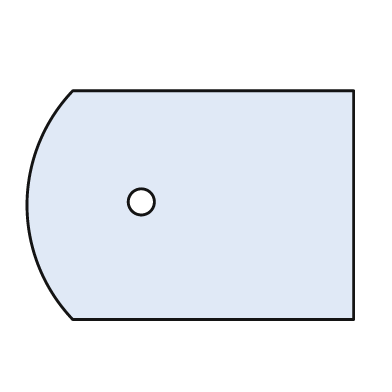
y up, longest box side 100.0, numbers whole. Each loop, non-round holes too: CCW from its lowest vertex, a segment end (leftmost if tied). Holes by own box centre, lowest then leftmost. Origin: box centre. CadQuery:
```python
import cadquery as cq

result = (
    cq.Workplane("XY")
    .moveTo(-36.0, -35.0)
    .lineTo(50.0, -35.0)
    .lineTo(50.0, 35.0)
    .lineTo(-36.0, 35.0)
    .threePointArc((-50.0, 0.0), (-36.0, -35.0))
    .close()
    .moveTo(-15.0, 1.0)
    .circle(4.0)
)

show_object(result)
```